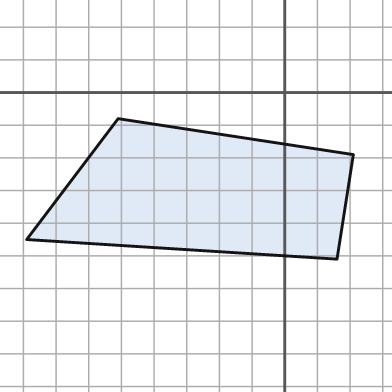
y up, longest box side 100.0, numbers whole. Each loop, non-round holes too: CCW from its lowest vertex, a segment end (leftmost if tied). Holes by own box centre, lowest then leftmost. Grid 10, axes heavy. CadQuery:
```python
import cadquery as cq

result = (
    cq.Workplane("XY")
    .moveTo(16.0, -51.0)
    .lineTo(21.0, -19.0)
    .lineTo(-51.0, -8.0)
    .lineTo(-79.0, -45.0)
    .close()
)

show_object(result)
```